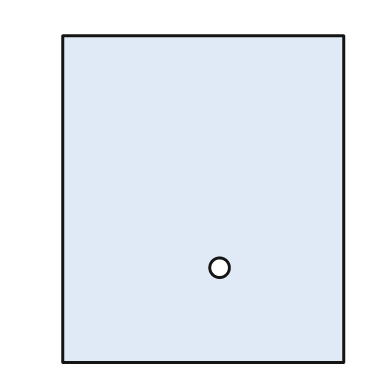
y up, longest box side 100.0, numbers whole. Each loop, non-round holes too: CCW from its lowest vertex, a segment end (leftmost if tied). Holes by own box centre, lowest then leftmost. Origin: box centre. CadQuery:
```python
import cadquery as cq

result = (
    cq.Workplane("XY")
    .moveTo(-43.0, -50.0)
    .lineTo(43.0, -50.0)
    .lineTo(43.0, 50.0)
    .lineTo(-43.0, 50.0)
    .close()
    .moveTo(5.0, -21.0)
    .circle(3.0)
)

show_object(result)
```